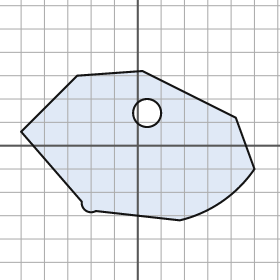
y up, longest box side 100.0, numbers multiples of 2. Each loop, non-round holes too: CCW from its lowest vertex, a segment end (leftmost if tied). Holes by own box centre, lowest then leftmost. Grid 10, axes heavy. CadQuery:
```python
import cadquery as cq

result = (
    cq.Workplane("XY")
    .moveTo(18.0, -32.0)
    .threePointArc((36.0, -24.0), (50.0, -10.0))
    .lineTo(42.0, 12.0)
    .lineTo(2.0, 32.0)
    .lineTo(-26.0, 30.0)
    .lineTo(-50.0, 6.0)
    .lineTo(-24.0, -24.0)
    .threePointArc((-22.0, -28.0), (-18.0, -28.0))
    .close()
    .moveTo(4.0, 14.0)
    .circle(6.0)
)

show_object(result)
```